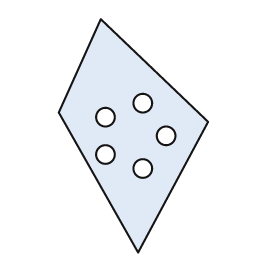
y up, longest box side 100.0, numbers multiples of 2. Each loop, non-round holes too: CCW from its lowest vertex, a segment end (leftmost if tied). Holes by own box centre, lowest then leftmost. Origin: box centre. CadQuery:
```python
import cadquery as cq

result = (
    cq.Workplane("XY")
    .moveTo(2.0, -50.0)
    .lineTo(32.0, 6.0)
    .lineTo(-14.0, 50.0)
    .lineTo(-32.0, 10.0)
    .close()
    .moveTo(4.0, -14.0)
    .circle(4.0)
    .moveTo(-12.0, -8.0)
    .circle(4.0)
    .moveTo(14.0, 0.0)
    .circle(4.0)
    .moveTo(-12.0, 8.0)
    .circle(4.0)
    .moveTo(4.0, 14.0)
    .circle(4.0)
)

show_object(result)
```